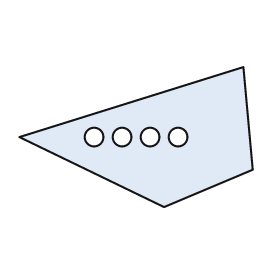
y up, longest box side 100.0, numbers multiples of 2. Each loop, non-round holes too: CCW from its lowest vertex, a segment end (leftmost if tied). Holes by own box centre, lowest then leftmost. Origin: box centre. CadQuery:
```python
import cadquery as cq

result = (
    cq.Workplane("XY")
    .moveTo(12.0, -30.0)
    .lineTo(50.0, -14.0)
    .lineTo(46.0, 30.0)
    .lineTo(-50.0, 0.0)
    .close()
    .moveTo(-18.0, 0.0)
    .circle(4.0)
    .moveTo(-6.0, 0.0)
    .circle(4.0)
    .moveTo(6.0, 0.0)
    .circle(4.0)
    .moveTo(18.0, 0.0)
    .circle(4.0)
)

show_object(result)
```